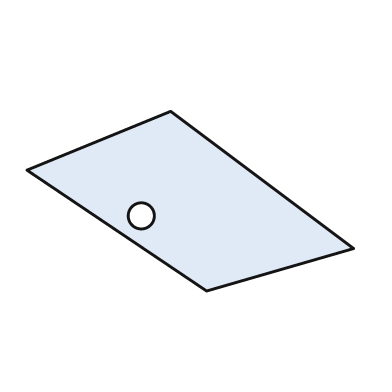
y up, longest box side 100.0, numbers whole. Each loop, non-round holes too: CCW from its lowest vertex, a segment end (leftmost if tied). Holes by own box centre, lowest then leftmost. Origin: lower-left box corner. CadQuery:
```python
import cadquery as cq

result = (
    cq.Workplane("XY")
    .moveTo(55.0, 0.0)
    .lineTo(100.0, 13.0)
    .lineTo(44.0, 55.0)
    .lineTo(0.0, 37.0)
    .close()
    .moveTo(35.0, 23.0)
    .circle(4.0)
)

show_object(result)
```